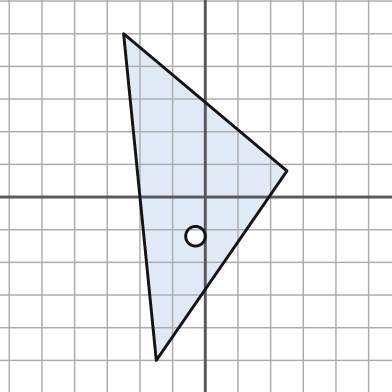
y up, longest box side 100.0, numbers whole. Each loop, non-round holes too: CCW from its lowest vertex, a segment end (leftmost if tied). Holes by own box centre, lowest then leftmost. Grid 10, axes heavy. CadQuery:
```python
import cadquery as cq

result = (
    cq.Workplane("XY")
    .moveTo(-15.0, -50.0)
    .lineTo(25.0, 8.0)
    .lineTo(-25.0, 50.0)
    .close()
    .moveTo(-3.0, -12.0)
    .circle(3.0)
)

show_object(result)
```